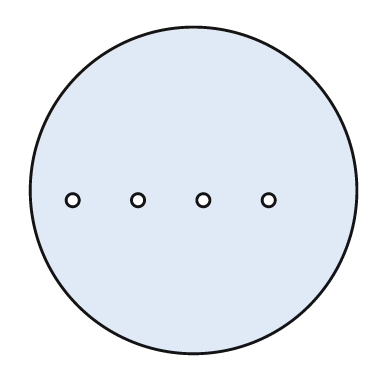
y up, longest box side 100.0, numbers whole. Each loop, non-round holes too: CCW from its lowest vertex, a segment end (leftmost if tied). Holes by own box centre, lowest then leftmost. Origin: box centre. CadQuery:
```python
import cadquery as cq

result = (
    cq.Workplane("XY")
    .moveTo(0.0, 0.0)
    .circle(50.0)
    .moveTo(-37.0, -3.0)
    .circle(2.0)
    .moveTo(-17.0, -3.0)
    .circle(2.0)
    .moveTo(3.0, -3.0)
    .circle(2.0)
    .moveTo(23.0, -3.0)
    .circle(2.0)
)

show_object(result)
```